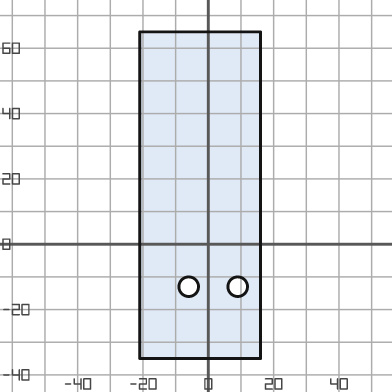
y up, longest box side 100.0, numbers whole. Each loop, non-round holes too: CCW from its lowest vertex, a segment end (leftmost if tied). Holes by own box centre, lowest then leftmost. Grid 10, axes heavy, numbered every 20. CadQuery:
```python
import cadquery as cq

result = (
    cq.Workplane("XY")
    .moveTo(-21.0, -35.0)
    .lineTo(16.0, -35.0)
    .lineTo(16.0, 65.0)
    .lineTo(-21.0, 65.0)
    .close()
    .moveTo(-6.0, -13.0)
    .circle(3.0)
    .moveTo(9.0, -13.0)
    .circle(3.0)
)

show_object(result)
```